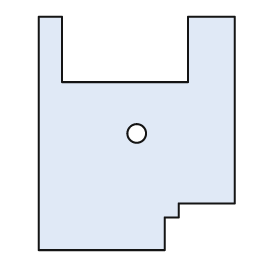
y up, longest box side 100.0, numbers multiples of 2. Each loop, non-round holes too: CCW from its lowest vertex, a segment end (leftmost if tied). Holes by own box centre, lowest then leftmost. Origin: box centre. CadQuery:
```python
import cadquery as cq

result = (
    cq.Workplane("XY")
    .moveTo(-42.0, -50.0)
    .lineTo(12.0, -50.0)
    .lineTo(12.0, -36.0)
    .lineTo(18.0, -36.0)
    .lineTo(18.0, -30.0)
    .lineTo(42.0, -30.0)
    .lineTo(42.0, 50.0)
    .lineTo(22.0, 50.0)
    .lineTo(22.0, 22.0)
    .lineTo(-32.0, 22.0)
    .lineTo(-32.0, 50.0)
    .lineTo(-42.0, 50.0)
    .close()
    .moveTo(0.0, 0.0)
    .circle(4.0)
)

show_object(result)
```